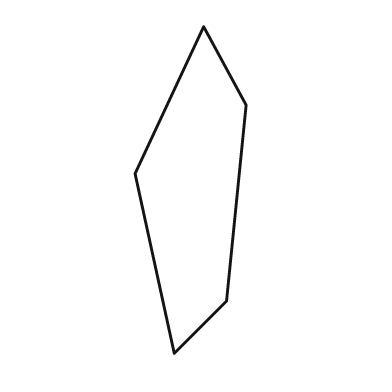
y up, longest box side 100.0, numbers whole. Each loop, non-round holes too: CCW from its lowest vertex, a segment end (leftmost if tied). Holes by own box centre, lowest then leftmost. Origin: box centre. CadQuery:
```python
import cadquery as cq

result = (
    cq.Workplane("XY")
    .moveTo(-5.0, -50.0)
    .lineTo(11.0, -34.0)
    .lineTo(17.0, 26.0)
    .lineTo(4.0, 50.0)
    .lineTo(-17.0, 5.0)
    .close()
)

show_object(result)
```